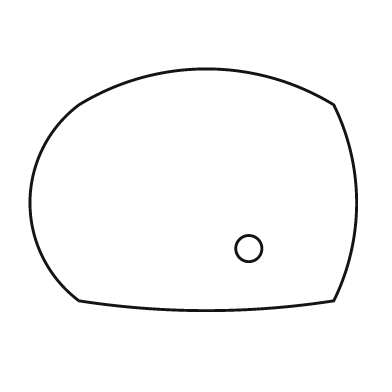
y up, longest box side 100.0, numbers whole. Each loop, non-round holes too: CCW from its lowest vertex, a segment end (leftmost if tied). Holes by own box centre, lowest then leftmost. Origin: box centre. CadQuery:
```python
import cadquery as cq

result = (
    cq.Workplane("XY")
    .moveTo(-35.0, -34.0)
    .threePointArc((4.0, -37.0), (43.0, -34.0))
    .threePointArc((50.0, -4.0), (43.0, 26.0))
    .threePointArc((4.0, 37.0), (-35.0, 26.0))
    .threePointArc((-50.0, -4.0), (-35.0, -34.0))
    .close()
    .moveTo(17.0, -18.0)
    .circle(4.0)
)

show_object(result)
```